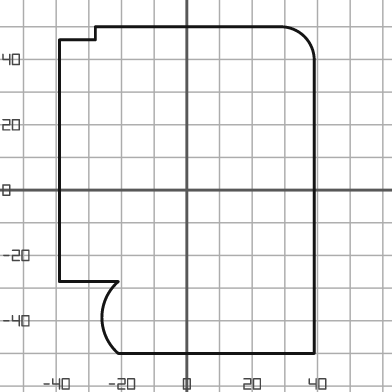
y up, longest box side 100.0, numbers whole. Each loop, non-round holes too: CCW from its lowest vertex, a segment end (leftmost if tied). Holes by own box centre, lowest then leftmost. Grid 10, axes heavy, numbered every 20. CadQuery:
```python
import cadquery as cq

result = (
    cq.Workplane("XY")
    .moveTo(-21.0, -50.0)
    .lineTo(39.0, -50.0)
    .lineTo(39.0, 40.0)
    .threePointArc((36.0, 47.0), (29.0, 50.0))
    .lineTo(-28.0, 50.0)
    .lineTo(-28.0, 46.0)
    .lineTo(-39.0, 46.0)
    .lineTo(-39.0, -28.0)
    .lineTo(-21.0, -28.0)
    .threePointArc((-26.0, -39.0), (-21.0, -50.0))
    .close()
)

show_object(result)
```